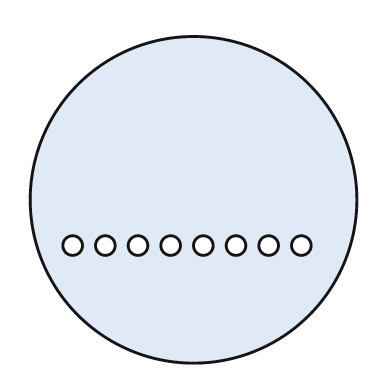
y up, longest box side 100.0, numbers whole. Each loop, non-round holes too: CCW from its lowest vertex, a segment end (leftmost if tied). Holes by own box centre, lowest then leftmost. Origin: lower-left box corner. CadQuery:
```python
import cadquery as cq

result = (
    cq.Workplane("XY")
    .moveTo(50.0, 50.0)
    .circle(50.0)
    .moveTo(13.0, 36.0)
    .circle(3.0)
    .moveTo(23.0, 36.0)
    .circle(3.0)
    .moveTo(33.0, 36.0)
    .circle(3.0)
    .moveTo(43.0, 36.0)
    .circle(3.0)
    .moveTo(53.0, 36.0)
    .circle(3.0)
    .moveTo(63.0, 36.0)
    .circle(3.0)
    .moveTo(73.0, 36.0)
    .circle(3.0)
    .moveTo(83.0, 36.0)
    .circle(3.0)
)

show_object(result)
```